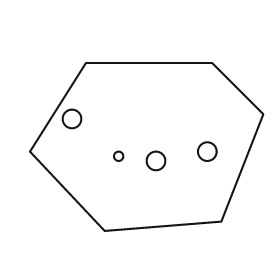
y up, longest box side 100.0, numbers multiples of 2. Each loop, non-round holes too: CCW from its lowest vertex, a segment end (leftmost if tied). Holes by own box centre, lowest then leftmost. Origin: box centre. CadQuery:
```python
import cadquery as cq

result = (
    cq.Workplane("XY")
    .moveTo(-18.0, -36.0)
    .lineTo(32.0, -32.0)
    .lineTo(50.0, 14.0)
    .lineTo(28.0, 36.0)
    .lineTo(-26.0, 36.0)
    .lineTo(-50.0, -2.0)
    .close()
    .moveTo(4.0, -6.0)
    .circle(4.0)
    .moveTo(-12.0, -4.0)
    .circle(2.0)
    .moveTo(26.0, -2.0)
    .circle(4.0)
    .moveTo(-32.0, 12.0)
    .circle(4.0)
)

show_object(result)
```